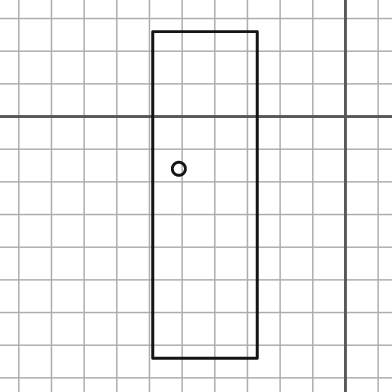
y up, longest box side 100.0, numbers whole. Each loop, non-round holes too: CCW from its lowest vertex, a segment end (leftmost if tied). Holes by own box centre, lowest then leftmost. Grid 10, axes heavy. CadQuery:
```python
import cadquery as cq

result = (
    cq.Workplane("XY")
    .moveTo(-59.0, -74.0)
    .lineTo(-27.0, -74.0)
    .lineTo(-27.0, 26.0)
    .lineTo(-59.0, 26.0)
    .close()
    .moveTo(-51.0, -16.0)
    .circle(2.0)
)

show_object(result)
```